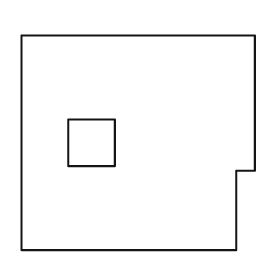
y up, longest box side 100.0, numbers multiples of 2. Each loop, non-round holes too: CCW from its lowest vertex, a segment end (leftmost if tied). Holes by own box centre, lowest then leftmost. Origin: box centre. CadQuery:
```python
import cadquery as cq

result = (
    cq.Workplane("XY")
    .moveTo(-50.0, -46.0)
    .lineTo(42.0, -46.0)
    .lineTo(42.0, -12.0)
    .lineTo(50.0, -12.0)
    .lineTo(50.0, 46.0)
    .lineTo(-50.0, 46.0)
    .close()
    .moveTo(-30.0, -10.0)
    .lineTo(-10.0, -10.0)
    .lineTo(-10.0, 10.0)
    .lineTo(-30.0, 10.0)
    .close()
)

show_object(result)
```